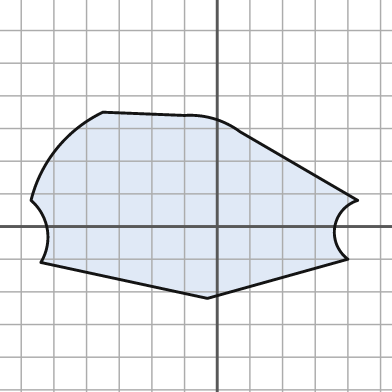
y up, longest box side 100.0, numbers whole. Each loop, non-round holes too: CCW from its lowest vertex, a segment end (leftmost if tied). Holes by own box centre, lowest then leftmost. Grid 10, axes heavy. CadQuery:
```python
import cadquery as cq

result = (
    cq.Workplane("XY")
    .moveTo(-3.0, -22.0)
    .lineTo(40.0, -10.0)
    .threePointArc((36.0, 0.0), (43.0, 8.0))
    .lineTo(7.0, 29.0)
    .threePointArc((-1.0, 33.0), (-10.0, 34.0))
    .lineTo(-35.0, 35.0)
    .threePointArc((-49.0, 24.0), (-57.0, 8.0))
    .threePointArc((-52.0, -1.0), (-54.0, -11.0))
    .close()
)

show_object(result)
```